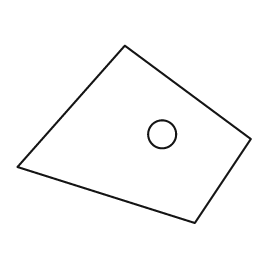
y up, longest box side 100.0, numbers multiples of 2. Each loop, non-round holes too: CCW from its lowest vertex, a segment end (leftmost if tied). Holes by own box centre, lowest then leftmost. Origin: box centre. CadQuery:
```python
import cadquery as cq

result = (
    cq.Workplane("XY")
    .moveTo(26.0, -38.0)
    .lineTo(50.0, -2.0)
    .lineTo(-4.0, 38.0)
    .lineTo(-50.0, -14.0)
    .close()
    .moveTo(12.0, 0.0)
    .circle(6.0)
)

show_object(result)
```